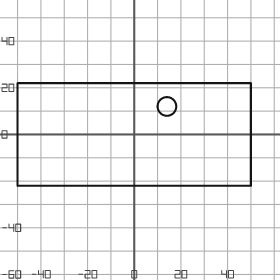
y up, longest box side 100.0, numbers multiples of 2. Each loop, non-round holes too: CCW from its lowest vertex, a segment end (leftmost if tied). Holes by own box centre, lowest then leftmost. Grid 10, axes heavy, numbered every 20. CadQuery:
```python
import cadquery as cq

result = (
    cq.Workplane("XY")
    .moveTo(-50.0, -22.0)
    .lineTo(50.0, -22.0)
    .lineTo(50.0, 22.0)
    .lineTo(-50.0, 22.0)
    .close()
    .moveTo(14.0, 12.0)
    .circle(4.0)
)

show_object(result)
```